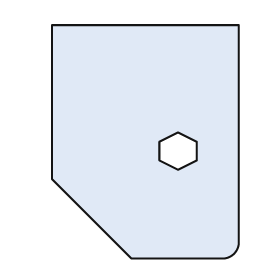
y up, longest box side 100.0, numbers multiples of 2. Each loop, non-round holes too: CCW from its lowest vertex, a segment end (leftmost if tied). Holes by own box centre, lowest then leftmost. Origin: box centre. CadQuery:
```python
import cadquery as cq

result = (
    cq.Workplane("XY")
    .moveTo(-6.0, -50.0)
    .lineTo(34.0, -50.0)
    .threePointArc((38.0, -48.0), (40.0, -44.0))
    .lineTo(40.0, 50.0)
    .lineTo(-40.0, 50.0)
    .lineTo(-40.0, -16.0)
    .close()
    .moveTo(14.0, -12.0)
    .lineTo(22.0, -8.0)
    .lineTo(22.0, 0.0)
    .lineTo(14.0, 4.0)
    .lineTo(6.0, 0.0)
    .lineTo(6.0, -8.0)
    .close()
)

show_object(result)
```